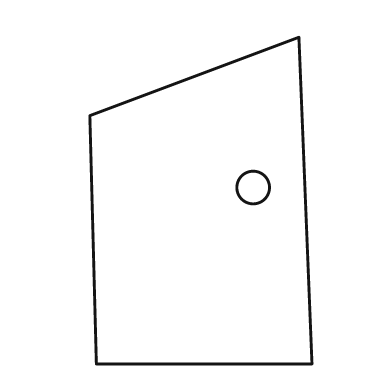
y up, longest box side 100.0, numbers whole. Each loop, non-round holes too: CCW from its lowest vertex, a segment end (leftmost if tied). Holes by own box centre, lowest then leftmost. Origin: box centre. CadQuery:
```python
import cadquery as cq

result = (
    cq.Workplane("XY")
    .moveTo(-32.0, -50.0)
    .lineTo(34.0, -50.0)
    .lineTo(30.0, 50.0)
    .lineTo(-34.0, 26.0)
    .close()
    .moveTo(16.0, 4.0)
    .circle(5.0)
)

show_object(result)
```